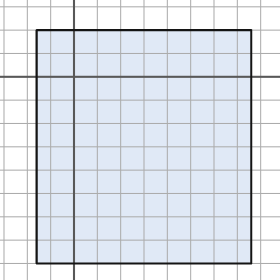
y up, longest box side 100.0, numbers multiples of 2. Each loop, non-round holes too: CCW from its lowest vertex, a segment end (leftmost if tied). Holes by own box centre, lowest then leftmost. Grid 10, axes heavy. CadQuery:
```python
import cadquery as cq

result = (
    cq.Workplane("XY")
    .moveTo(-16.0, -80.0)
    .lineTo(76.0, -80.0)
    .lineTo(76.0, 20.0)
    .lineTo(-16.0, 20.0)
    .close()
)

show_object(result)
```